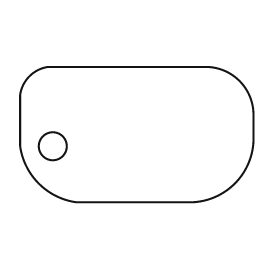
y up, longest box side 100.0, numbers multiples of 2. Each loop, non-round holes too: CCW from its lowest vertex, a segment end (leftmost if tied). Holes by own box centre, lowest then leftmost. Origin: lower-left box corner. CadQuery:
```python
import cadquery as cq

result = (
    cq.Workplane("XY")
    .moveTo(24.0, 0.0)
    .lineTo(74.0, 0.0)
    .threePointArc((92.0, 8.0), (100.0, 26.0))
    .lineTo(100.0, 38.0)
    .threePointArc((94.0, 52.0), (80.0, 58.0))
    .lineTo(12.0, 58.0)
    .threePointArc((4.0, 54.0), (0.0, 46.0))
    .lineTo(0.0, 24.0)
    .threePointArc((8.0, 8.0), (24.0, 0.0))
    .close()
    .moveTo(14.0, 24.0)
    .circle(6.0)
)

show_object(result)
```